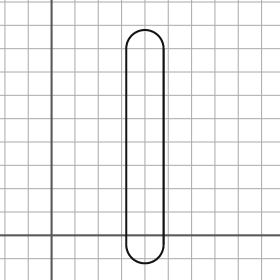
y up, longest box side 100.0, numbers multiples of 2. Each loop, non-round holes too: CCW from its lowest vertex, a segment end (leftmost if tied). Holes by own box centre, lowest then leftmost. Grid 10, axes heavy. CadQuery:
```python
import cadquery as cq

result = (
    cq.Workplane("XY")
    .moveTo(32.0, -4.0)
    .threePointArc((40.0, -12.0), (48.0, -4.0))
    .lineTo(48.0, 80.0)
    .threePointArc((40.0, 88.0), (32.0, 80.0))
    .close()
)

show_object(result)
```